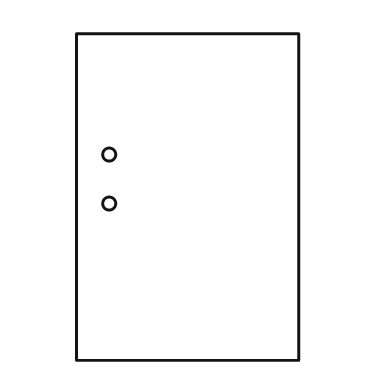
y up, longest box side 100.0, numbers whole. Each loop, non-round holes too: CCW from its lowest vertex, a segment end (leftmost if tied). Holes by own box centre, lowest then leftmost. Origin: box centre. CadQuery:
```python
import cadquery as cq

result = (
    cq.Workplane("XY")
    .moveTo(-34.0, -50.0)
    .lineTo(34.0, -50.0)
    .lineTo(34.0, 50.0)
    .lineTo(-34.0, 50.0)
    .close()
    .moveTo(-24.0, -2.0)
    .circle(2.0)
    .moveTo(-24.0, 13.0)
    .circle(2.0)
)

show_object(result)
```